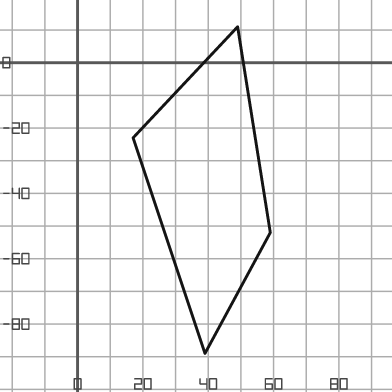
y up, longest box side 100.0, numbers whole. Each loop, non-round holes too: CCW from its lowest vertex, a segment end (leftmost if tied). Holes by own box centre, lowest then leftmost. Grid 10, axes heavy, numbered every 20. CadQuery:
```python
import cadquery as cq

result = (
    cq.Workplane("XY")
    .moveTo(39.0, -89.0)
    .lineTo(59.0, -52.0)
    .lineTo(49.0, 11.0)
    .lineTo(17.0, -23.0)
    .close()
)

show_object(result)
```